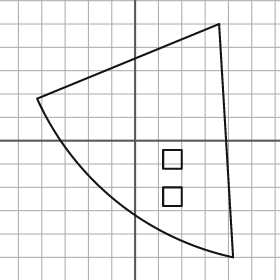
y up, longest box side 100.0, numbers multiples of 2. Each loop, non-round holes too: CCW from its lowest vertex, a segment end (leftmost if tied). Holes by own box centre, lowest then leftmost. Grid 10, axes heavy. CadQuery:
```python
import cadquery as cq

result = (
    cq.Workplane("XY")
    .moveTo(42.0, -50.0)
    .lineTo(36.0, 50.0)
    .lineTo(-42.0, 18.0)
    .threePointArc((-8.0, -26.0), (42.0, -50.0))
    .close()
    .moveTo(12.0, -28.0)
    .lineTo(20.0, -28.0)
    .lineTo(20.0, -20.0)
    .lineTo(12.0, -20.0)
    .close()
    .moveTo(12.0, -12.0)
    .lineTo(20.0, -12.0)
    .lineTo(20.0, -4.0)
    .lineTo(12.0, -4.0)
    .close()
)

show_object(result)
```